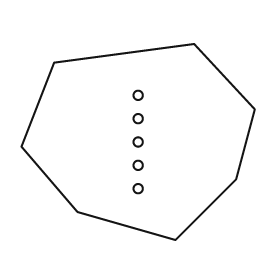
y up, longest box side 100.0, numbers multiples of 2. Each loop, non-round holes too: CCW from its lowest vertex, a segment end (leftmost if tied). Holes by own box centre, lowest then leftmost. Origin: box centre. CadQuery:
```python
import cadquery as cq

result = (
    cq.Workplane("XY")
    .moveTo(16.0, -42.0)
    .lineTo(42.0, -16.0)
    .lineTo(50.0, 14.0)
    .lineTo(24.0, 42.0)
    .lineTo(-36.0, 34.0)
    .lineTo(-50.0, -2.0)
    .lineTo(-26.0, -30.0)
    .close()
    .moveTo(0.0, -20.0)
    .circle(2.0)
    .moveTo(0.0, -10.0)
    .circle(2.0)
    .moveTo(0.0, 0.0)
    .circle(2.0)
    .moveTo(0.0, 10.0)
    .circle(2.0)
    .moveTo(0.0, 20.0)
    .circle(2.0)
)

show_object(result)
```